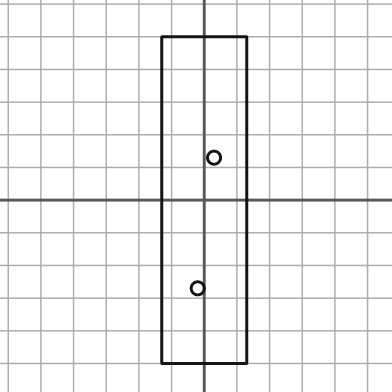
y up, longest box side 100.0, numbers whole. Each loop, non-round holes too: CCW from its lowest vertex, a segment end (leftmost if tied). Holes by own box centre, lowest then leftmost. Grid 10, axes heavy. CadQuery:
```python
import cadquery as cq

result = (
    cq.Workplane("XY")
    .moveTo(-13.0, -50.0)
    .lineTo(13.0, -50.0)
    .lineTo(13.0, 50.0)
    .lineTo(-13.0, 50.0)
    .close()
    .moveTo(-2.0, -27.0)
    .circle(2.0)
    .moveTo(3.0, 13.0)
    .circle(2.0)
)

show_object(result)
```